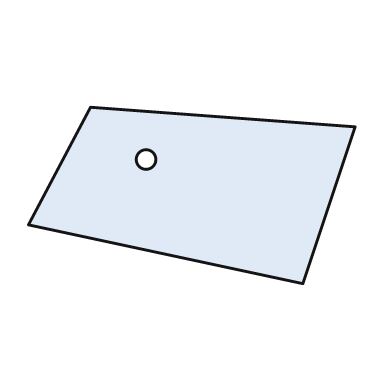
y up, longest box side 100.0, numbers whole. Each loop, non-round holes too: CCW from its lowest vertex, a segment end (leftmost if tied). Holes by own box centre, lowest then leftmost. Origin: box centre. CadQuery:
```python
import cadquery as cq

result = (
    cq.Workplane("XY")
    .moveTo(34.0, -27.0)
    .lineTo(50.0, 21.0)
    .lineTo(-31.0, 27.0)
    .lineTo(-50.0, -9.0)
    .close()
    .moveTo(-14.0, 11.0)
    .circle(3.0)
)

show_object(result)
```